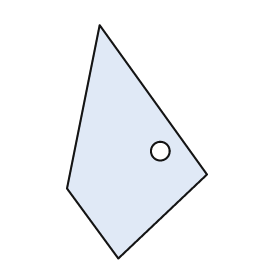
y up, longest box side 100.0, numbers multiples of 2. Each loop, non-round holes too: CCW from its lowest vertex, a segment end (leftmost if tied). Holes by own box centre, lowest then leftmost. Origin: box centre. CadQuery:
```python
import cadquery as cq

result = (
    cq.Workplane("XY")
    .moveTo(-8.0, -50.0)
    .lineTo(30.0, -14.0)
    .lineTo(-16.0, 50.0)
    .lineTo(-30.0, -20.0)
    .close()
    .moveTo(10.0, -4.0)
    .circle(4.0)
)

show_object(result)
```